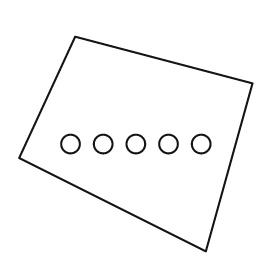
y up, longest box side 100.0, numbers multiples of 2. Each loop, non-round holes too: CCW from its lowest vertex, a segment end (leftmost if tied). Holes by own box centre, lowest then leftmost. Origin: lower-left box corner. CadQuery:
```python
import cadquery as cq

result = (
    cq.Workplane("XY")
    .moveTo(80.0, 0.0)
    .lineTo(100.0, 72.0)
    .lineTo(24.0, 92.0)
    .lineTo(0.0, 40.0)
    .close()
    .moveTo(22.0, 46.0)
    .circle(4.0)
    .moveTo(36.0, 46.0)
    .circle(4.0)
    .moveTo(50.0, 46.0)
    .circle(4.0)
    .moveTo(64.0, 46.0)
    .circle(4.0)
    .moveTo(78.0, 46.0)
    .circle(4.0)
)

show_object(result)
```